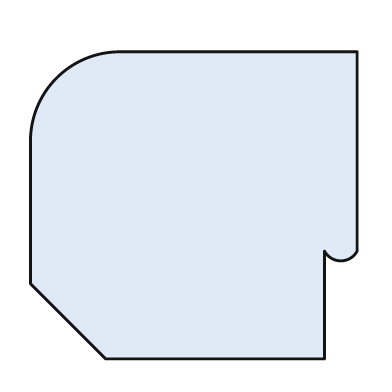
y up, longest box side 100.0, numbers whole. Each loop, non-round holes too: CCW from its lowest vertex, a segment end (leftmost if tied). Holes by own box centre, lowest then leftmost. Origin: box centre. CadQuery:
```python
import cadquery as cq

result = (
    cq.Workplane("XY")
    .moveTo(-27.0, -47.0)
    .lineTo(40.0, -47.0)
    .lineTo(40.0, -14.0)
    .threePointArc((45.0, -17.0), (50.0, -14.0))
    .lineTo(50.0, 47.0)
    .lineTo(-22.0, 47.0)
    .threePointArc((-42.0, 39.0), (-50.0, 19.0))
    .lineTo(-50.0, -24.0)
    .close()
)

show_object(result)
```